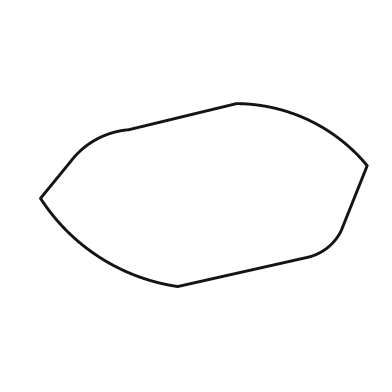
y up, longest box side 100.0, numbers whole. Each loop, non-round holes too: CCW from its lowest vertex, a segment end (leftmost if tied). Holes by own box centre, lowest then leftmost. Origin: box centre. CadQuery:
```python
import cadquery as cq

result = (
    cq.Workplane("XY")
    .moveTo(-8.0, -28.0)
    .lineTo(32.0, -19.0)
    .threePointArc((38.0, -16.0), (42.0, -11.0))
    .lineTo(50.0, 9.0)
    .threePointArc((32.0, 23.0), (10.0, 28.0))
    .lineTo(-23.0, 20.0)
    .threePointArc((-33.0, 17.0), (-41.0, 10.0))
    .lineTo(-50.0, -1.0)
    .threePointArc((-32.0, -19.0), (-8.0, -28.0))
    .close()
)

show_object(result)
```